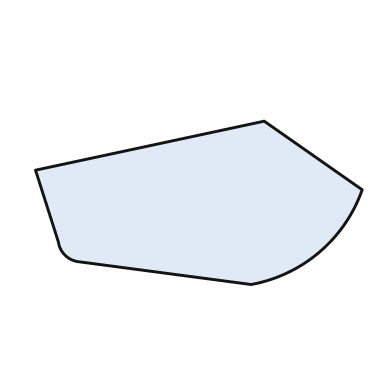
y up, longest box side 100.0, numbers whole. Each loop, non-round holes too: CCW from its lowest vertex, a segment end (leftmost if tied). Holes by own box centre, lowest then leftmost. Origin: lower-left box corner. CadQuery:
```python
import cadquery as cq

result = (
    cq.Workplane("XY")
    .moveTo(66.0, 0.0)
    .threePointArc((87.0, 10.0), (100.0, 29.0))
    .lineTo(70.0, 50.0)
    .lineTo(0.0, 35.0)
    .lineTo(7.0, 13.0)
    .threePointArc((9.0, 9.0), (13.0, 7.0))
    .close()
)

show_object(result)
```